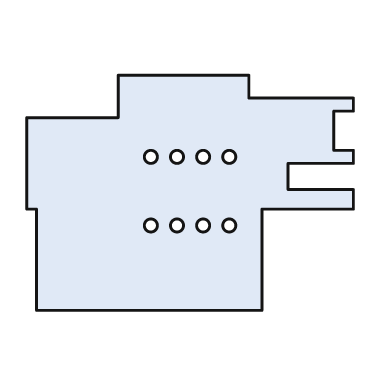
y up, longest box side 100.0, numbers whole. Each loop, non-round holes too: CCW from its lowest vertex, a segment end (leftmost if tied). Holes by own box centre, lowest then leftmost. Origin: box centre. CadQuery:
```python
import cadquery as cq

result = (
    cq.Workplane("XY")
    .moveTo(-47.0, -36.0)
    .lineTo(22.0, -36.0)
    .lineTo(22.0, -5.0)
    .lineTo(50.0, -5.0)
    .lineTo(50.0, 1.0)
    .lineTo(30.0, 1.0)
    .lineTo(30.0, 9.0)
    .lineTo(50.0, 9.0)
    .lineTo(50.0, 13.0)
    .lineTo(44.0, 13.0)
    .lineTo(44.0, 25.0)
    .lineTo(50.0, 25.0)
    .lineTo(50.0, 29.0)
    .lineTo(18.0, 29.0)
    .lineTo(18.0, 36.0)
    .lineTo(-22.0, 36.0)
    .lineTo(-22.0, 23.0)
    .lineTo(-50.0, 23.0)
    .lineTo(-50.0, -5.0)
    .lineTo(-47.0, -5.0)
    .close()
    .moveTo(-12.0, -10.0)
    .circle(2.0)
    .moveTo(-4.0, -10.0)
    .circle(2.0)
    .moveTo(4.0, -10.0)
    .circle(2.0)
    .moveTo(12.0, -10.0)
    .circle(2.0)
    .moveTo(-12.0, 11.0)
    .circle(2.0)
    .moveTo(-4.0, 11.0)
    .circle(2.0)
    .moveTo(4.0, 11.0)
    .circle(2.0)
    .moveTo(12.0, 11.0)
    .circle(2.0)
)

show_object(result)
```